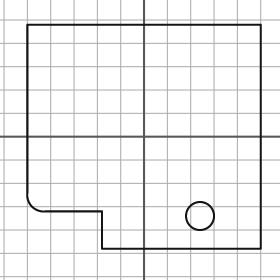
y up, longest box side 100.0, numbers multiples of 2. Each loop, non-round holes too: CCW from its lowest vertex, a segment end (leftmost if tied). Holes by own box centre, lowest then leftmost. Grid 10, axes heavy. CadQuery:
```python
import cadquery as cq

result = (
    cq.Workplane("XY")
    .moveTo(-18.0, -48.0)
    .lineTo(50.0, -48.0)
    .lineTo(50.0, 48.0)
    .lineTo(-50.0, 48.0)
    .lineTo(-50.0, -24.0)
    .threePointArc((-48.0, -30.0), (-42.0, -32.0))
    .lineTo(-18.0, -32.0)
    .close()
    .moveTo(24.0, -34.0)
    .circle(6.0)
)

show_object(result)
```